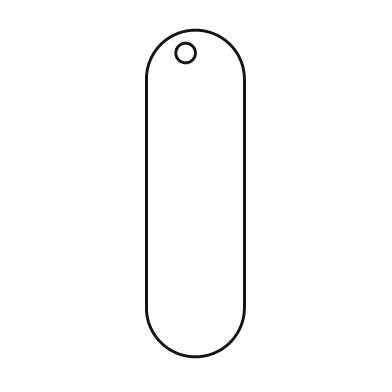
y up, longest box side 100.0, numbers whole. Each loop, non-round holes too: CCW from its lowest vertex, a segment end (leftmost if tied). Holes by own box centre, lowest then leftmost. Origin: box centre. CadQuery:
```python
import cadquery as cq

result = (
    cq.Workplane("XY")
    .moveTo(-15.0, -35.0)
    .threePointArc((0.0, -50.0), (15.0, -35.0))
    .lineTo(15.0, 35.0)
    .threePointArc((0.0, 50.0), (-15.0, 35.0))
    .close()
    .moveTo(-3.0, 43.0)
    .circle(3.0)
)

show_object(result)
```